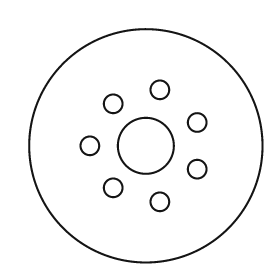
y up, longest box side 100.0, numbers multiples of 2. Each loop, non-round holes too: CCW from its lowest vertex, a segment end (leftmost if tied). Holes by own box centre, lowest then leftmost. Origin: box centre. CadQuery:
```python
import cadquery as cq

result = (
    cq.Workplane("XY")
    .moveTo(0.0, 0.0)
    .circle(50.0)
    .moveTo(6.0, -24.0)
    .circle(4.0)
    .moveTo(-14.0, -18.0)
    .circle(4.0)
    .moveTo(22.0, -10.0)
    .circle(4.0)
    .moveTo(-24.0, 0.0)
    .circle(4.0)
    .moveTo(0.0, 0.0)
    .circle(12.0)
    .moveTo(22.0, 10.0)
    .circle(4.0)
    .moveTo(-14.0, 18.0)
    .circle(4.0)
    .moveTo(6.0, 24.0)
    .circle(4.0)
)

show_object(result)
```